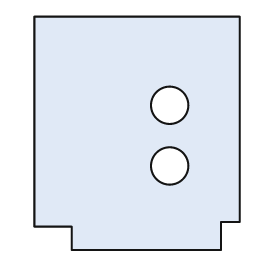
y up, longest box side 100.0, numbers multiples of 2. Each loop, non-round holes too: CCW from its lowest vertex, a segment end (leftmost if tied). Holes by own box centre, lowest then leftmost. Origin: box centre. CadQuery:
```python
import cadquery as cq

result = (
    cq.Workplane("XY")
    .moveTo(-28.0, -50.0)
    .lineTo(36.0, -50.0)
    .lineTo(36.0, -38.0)
    .lineTo(44.0, -38.0)
    .lineTo(44.0, 50.0)
    .lineTo(-44.0, 50.0)
    .lineTo(-44.0, -40.0)
    .lineTo(-28.0, -40.0)
    .close()
    .moveTo(14.0, -14.0)
    .circle(8.0)
    .moveTo(14.0, 12.0)
    .circle(8.0)
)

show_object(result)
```